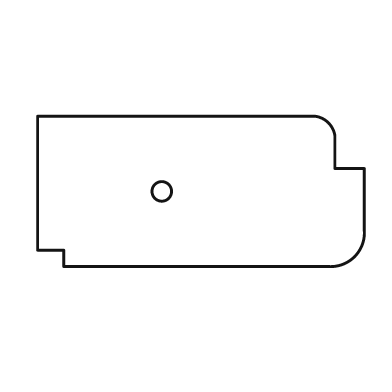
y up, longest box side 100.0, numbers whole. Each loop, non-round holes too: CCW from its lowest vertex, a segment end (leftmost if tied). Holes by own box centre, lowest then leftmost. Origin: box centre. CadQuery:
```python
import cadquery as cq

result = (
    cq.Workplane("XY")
    .moveTo(-42.0, -23.0)
    .lineTo(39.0, -23.0)
    .threePointArc((47.0, -20.0), (50.0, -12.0))
    .lineTo(50.0, 7.0)
    .lineTo(41.0, 7.0)
    .lineTo(41.0, 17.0)
    .threePointArc((39.0, 21.0), (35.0, 23.0))
    .lineTo(-50.0, 23.0)
    .lineTo(-50.0, -18.0)
    .lineTo(-42.0, -18.0)
    .close()
    .moveTo(-12.0, 0.0)
    .circle(3.0)
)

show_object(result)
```